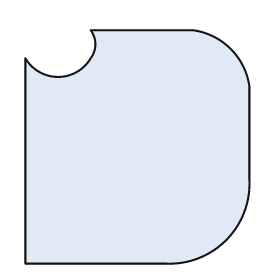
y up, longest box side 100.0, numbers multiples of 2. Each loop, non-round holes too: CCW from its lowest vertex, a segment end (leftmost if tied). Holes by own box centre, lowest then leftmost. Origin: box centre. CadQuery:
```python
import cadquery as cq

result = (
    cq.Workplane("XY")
    .moveTo(-48.0, -50.0)
    .lineTo(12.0, -50.0)
    .threePointArc((38.0, -40.0), (48.0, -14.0))
    .lineTo(48.0, 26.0)
    .threePointArc((40.0, 42.0), (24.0, 50.0))
    .lineTo(-20.0, 50.0)
    .threePointArc((-18.0, 44.0), (-20.0, 38.0))
    .threePointArc((-34.0, 30.0), (-48.0, 38.0))
    .close()
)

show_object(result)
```